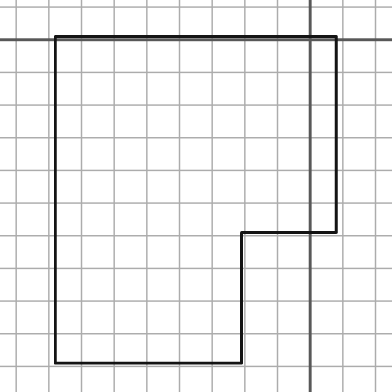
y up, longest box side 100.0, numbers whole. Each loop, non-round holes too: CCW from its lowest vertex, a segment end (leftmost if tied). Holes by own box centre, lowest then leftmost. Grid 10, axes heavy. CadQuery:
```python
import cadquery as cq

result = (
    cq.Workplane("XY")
    .moveTo(-78.0, -99.0)
    .lineTo(-21.0, -99.0)
    .lineTo(-21.0, -59.0)
    .lineTo(8.0, -59.0)
    .lineTo(8.0, 1.0)
    .lineTo(-78.0, 1.0)
    .close()
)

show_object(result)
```